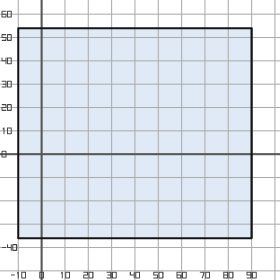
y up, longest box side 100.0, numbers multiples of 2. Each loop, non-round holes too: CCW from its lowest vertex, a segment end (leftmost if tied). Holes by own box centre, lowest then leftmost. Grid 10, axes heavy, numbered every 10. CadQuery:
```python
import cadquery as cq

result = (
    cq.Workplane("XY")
    .moveTo(-10.0, -36.0)
    .lineTo(90.0, -36.0)
    .lineTo(90.0, 54.0)
    .lineTo(-10.0, 54.0)
    .close()
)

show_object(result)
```